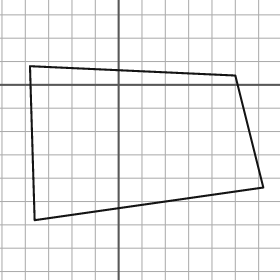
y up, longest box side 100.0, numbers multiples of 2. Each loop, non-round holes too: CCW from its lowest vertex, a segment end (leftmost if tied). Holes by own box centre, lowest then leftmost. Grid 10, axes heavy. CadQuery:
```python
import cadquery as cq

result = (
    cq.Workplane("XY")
    .moveTo(-36.0, -58.0)
    .lineTo(62.0, -44.0)
    .lineTo(50.0, 4.0)
    .lineTo(-38.0, 8.0)
    .close()
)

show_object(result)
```